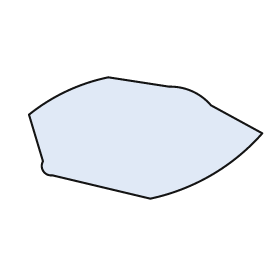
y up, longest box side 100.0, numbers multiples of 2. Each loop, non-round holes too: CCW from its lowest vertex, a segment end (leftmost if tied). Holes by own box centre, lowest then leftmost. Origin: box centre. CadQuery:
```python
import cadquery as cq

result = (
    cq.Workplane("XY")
    .moveTo(2.0, -26.0)
    .threePointArc((28.0, -16.0), (50.0, 2.0))
    .lineTo(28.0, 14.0)
    .threePointArc((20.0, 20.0), (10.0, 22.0))
    .lineTo(-16.0, 26.0)
    .threePointArc((-34.0, 20.0), (-50.0, 10.0))
    .lineTo(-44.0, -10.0)
    .threePointArc((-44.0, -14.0), (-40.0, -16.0))
    .close()
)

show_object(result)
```